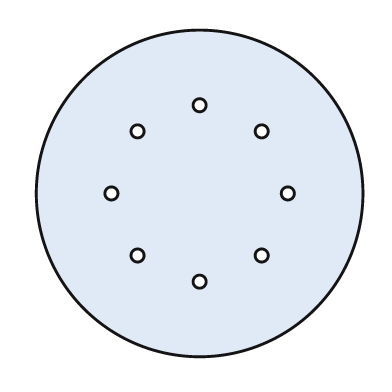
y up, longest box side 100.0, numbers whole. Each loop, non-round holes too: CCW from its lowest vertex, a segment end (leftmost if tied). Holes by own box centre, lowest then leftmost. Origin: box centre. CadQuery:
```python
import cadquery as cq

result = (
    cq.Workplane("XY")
    .moveTo(0.0, 0.0)
    .circle(50.0)
    .moveTo(0.0, -27.0)
    .circle(2.0)
    .moveTo(-19.0, -19.0)
    .circle(2.0)
    .moveTo(19.0, -19.0)
    .circle(2.0)
    .moveTo(-27.0, 0.0)
    .circle(2.0)
    .moveTo(27.0, 0.0)
    .circle(2.0)
    .moveTo(-19.0, 19.0)
    .circle(2.0)
    .moveTo(19.0, 19.0)
    .circle(2.0)
    .moveTo(0.0, 27.0)
    .circle(2.0)
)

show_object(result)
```